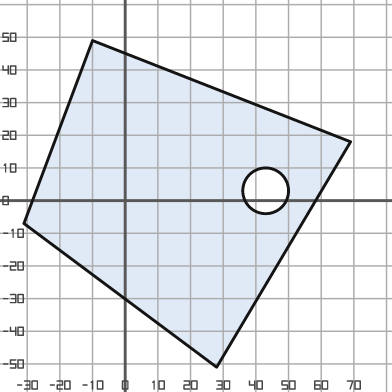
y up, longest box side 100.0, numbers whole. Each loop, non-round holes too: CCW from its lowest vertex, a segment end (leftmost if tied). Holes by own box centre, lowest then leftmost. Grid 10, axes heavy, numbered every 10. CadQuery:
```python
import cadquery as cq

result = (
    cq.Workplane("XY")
    .moveTo(28.0, -51.0)
    .lineTo(69.0, 18.0)
    .lineTo(-10.0, 49.0)
    .lineTo(-31.0, -7.0)
    .close()
    .moveTo(43.0, 3.0)
    .circle(7.0)
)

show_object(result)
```